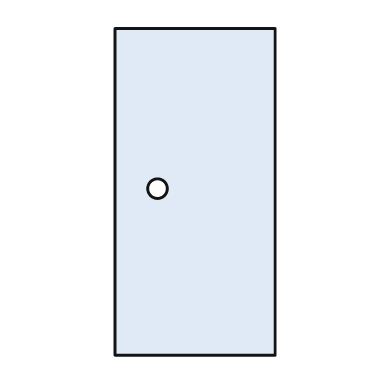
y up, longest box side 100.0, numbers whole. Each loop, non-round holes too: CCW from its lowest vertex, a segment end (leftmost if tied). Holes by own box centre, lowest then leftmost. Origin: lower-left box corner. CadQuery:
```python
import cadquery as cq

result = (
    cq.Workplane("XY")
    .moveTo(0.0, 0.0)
    .lineTo(49.0, 0.0)
    .lineTo(49.0, 100.0)
    .lineTo(0.0, 100.0)
    .close()
    .moveTo(13.0, 51.0)
    .circle(3.0)
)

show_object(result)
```